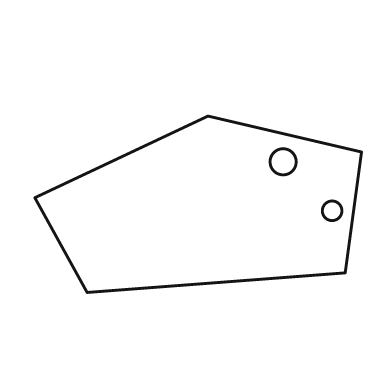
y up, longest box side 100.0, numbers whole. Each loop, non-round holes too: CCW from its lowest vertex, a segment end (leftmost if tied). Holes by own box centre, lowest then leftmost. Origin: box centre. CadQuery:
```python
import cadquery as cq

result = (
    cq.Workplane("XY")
    .moveTo(-34.0, -27.0)
    .lineTo(45.0, -21.0)
    .lineTo(50.0, 16.0)
    .lineTo(3.0, 27.0)
    .lineTo(-50.0, 2.0)
    .close()
    .moveTo(41.0, -2.0)
    .circle(3.0)
    .moveTo(26.0, 13.0)
    .circle(4.0)
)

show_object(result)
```